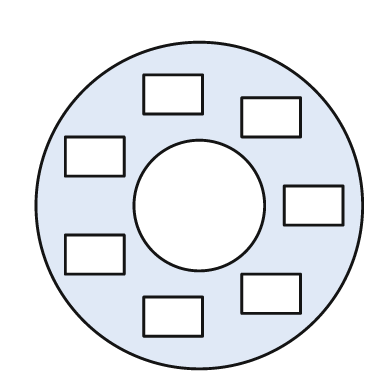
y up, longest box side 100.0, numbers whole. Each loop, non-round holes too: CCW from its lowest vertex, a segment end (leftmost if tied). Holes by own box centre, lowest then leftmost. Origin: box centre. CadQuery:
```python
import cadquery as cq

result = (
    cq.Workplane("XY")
    .moveTo(0.0, 0.0)
    .circle(50.0)
    .moveTo(-17.0, -40.0)
    .lineTo(1.0, -40.0)
    .lineTo(1.0, -28.0)
    .lineTo(-17.0, -28.0)
    .close()
    .moveTo(13.0, -33.0)
    .lineTo(31.0, -33.0)
    .lineTo(31.0, -21.0)
    .lineTo(13.0, -21.0)
    .close()
    .moveTo(-41.0, -21.0)
    .lineTo(-23.0, -21.0)
    .lineTo(-23.0, -9.0)
    .lineTo(-41.0, -9.0)
    .close()
    .moveTo(0.0, 0.0)
    .circle(20.0)
    .moveTo(26.0, -6.0)
    .lineTo(44.0, -6.0)
    .lineTo(44.0, 6.0)
    .lineTo(26.0, 6.0)
    .close()
    .moveTo(-41.0, 9.0)
    .lineTo(-23.0, 9.0)
    .lineTo(-23.0, 21.0)
    .lineTo(-41.0, 21.0)
    .close()
    .moveTo(13.0, 21.0)
    .lineTo(31.0, 21.0)
    .lineTo(31.0, 33.0)
    .lineTo(13.0, 33.0)
    .close()
    .moveTo(-17.0, 28.0)
    .lineTo(1.0, 28.0)
    .lineTo(1.0, 40.0)
    .lineTo(-17.0, 40.0)
    .close()
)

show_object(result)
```